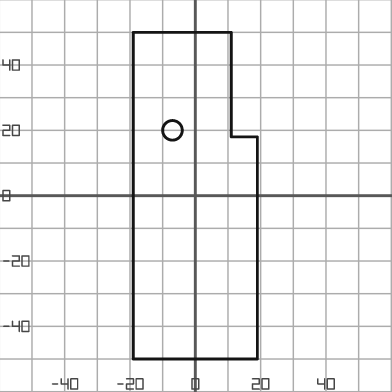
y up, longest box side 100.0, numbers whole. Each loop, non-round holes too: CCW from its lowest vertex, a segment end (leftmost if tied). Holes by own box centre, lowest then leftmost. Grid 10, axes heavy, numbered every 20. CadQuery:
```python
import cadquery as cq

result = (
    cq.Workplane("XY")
    .moveTo(-19.0, -50.0)
    .lineTo(19.0, -50.0)
    .lineTo(19.0, 18.0)
    .lineTo(11.0, 18.0)
    .lineTo(11.0, 50.0)
    .lineTo(-19.0, 50.0)
    .close()
    .moveTo(-7.0, 20.0)
    .circle(3.0)
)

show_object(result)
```